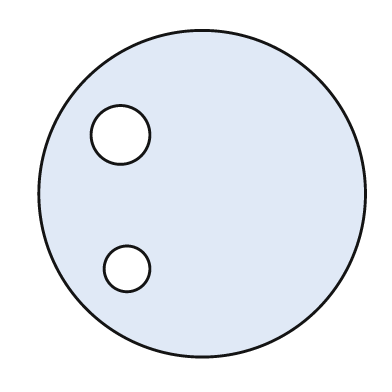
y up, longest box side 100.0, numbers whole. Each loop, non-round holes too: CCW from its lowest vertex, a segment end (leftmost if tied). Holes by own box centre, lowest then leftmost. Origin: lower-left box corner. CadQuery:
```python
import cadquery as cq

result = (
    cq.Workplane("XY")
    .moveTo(50.0, 50.0)
    .circle(50.0)
    .moveTo(27.0, 27.0)
    .circle(7.0)
    .moveTo(25.0, 68.0)
    .circle(9.0)
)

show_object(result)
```